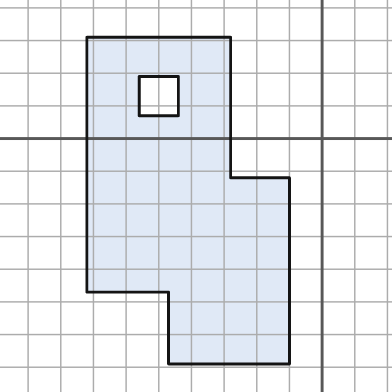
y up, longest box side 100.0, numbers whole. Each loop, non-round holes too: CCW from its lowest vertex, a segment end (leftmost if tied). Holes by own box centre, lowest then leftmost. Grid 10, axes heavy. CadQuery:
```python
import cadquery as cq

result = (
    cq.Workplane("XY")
    .moveTo(-47.0, -69.0)
    .lineTo(-10.0, -69.0)
    .lineTo(-10.0, -12.0)
    .lineTo(-28.0, -12.0)
    .lineTo(-28.0, 31.0)
    .lineTo(-72.0, 31.0)
    .lineTo(-72.0, -47.0)
    .lineTo(-47.0, -47.0)
    .close()
    .moveTo(-56.0, 7.0)
    .lineTo(-44.0, 7.0)
    .lineTo(-44.0, 19.0)
    .lineTo(-56.0, 19.0)
    .close()
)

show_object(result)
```